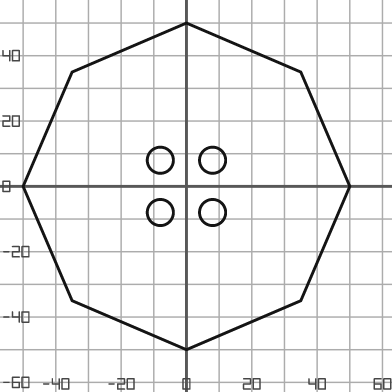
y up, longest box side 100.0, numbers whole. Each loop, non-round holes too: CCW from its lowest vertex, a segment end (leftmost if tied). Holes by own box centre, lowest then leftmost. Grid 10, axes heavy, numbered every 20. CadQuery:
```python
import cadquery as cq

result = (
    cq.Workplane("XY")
    .moveTo(0.0, -50.0)
    .lineTo(35.0, -35.0)
    .lineTo(50.0, 0.0)
    .lineTo(35.0, 35.0)
    .lineTo(0.0, 50.0)
    .lineTo(-35.0, 35.0)
    .lineTo(-50.0, 0.0)
    .lineTo(-35.0, -35.0)
    .close()
    .moveTo(-8.0, -8.0)
    .circle(4.0)
    .moveTo(8.0, -8.0)
    .circle(4.0)
    .moveTo(-8.0, 8.0)
    .circle(4.0)
    .moveTo(8.0, 8.0)
    .circle(4.0)
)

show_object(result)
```